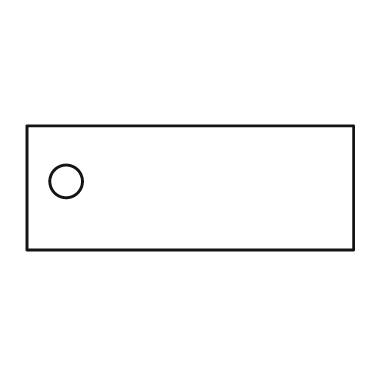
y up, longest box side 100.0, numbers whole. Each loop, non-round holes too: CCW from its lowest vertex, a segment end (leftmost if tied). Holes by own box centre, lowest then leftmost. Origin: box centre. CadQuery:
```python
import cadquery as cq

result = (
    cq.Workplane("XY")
    .moveTo(-50.0, -19.0)
    .lineTo(50.0, -19.0)
    .lineTo(50.0, 19.0)
    .lineTo(-50.0, 19.0)
    .close()
    .moveTo(-38.0, 2.0)
    .circle(5.0)
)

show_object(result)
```